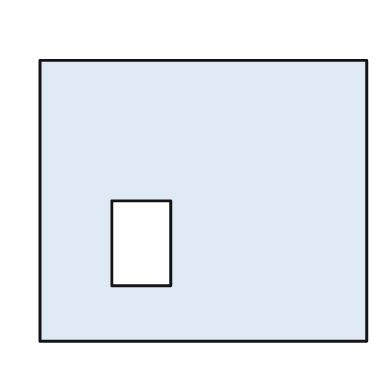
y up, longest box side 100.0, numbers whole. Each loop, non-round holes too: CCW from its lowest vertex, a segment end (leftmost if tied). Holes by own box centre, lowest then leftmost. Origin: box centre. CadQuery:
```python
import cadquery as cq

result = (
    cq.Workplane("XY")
    .moveTo(-50.0, -43.0)
    .lineTo(50.0, -43.0)
    .lineTo(50.0, 43.0)
    .lineTo(-50.0, 43.0)
    .close()
    .moveTo(-28.0, -26.0)
    .lineTo(-10.0, -26.0)
    .lineTo(-10.0, 0.0)
    .lineTo(-28.0, 0.0)
    .close()
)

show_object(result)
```